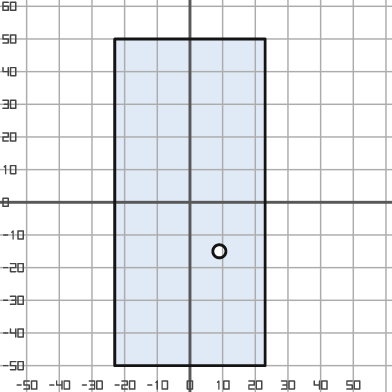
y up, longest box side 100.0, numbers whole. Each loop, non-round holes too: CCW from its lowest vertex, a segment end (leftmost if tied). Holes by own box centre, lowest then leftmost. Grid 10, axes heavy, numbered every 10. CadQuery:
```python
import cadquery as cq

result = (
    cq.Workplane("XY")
    .moveTo(-23.0, -50.0)
    .lineTo(23.0, -50.0)
    .lineTo(23.0, 50.0)
    .lineTo(-23.0, 50.0)
    .close()
    .moveTo(9.0, -15.0)
    .circle(2.0)
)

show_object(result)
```